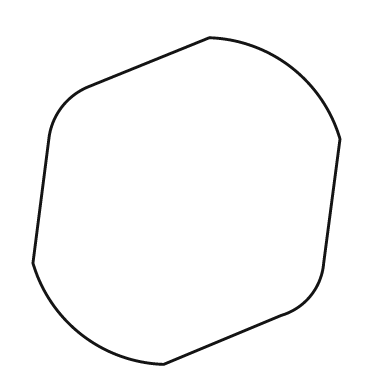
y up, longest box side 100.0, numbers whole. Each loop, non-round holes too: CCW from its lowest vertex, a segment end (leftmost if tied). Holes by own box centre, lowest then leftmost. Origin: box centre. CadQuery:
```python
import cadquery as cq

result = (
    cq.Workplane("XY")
    .moveTo(-7.0, -50.0)
    .lineTo(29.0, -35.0)
    .threePointArc((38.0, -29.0), (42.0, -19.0))
    .lineTo(47.0, 19.0)
    .threePointArc((32.0, 41.0), (7.0, 50.0))
    .lineTo(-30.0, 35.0)
    .threePointArc((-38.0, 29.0), (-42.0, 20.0))
    .lineTo(-47.0, -19.0)
    .threePointArc((-32.0, -41.0), (-7.0, -50.0))
    .close()
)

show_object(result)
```